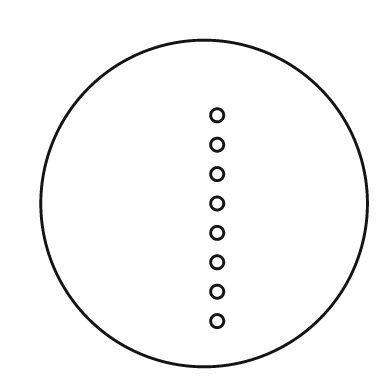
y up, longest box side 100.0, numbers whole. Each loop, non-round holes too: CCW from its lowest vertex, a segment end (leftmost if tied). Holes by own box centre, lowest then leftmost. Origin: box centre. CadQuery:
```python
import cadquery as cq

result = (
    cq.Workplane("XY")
    .moveTo(0.0, 0.0)
    .circle(50.0)
    .moveTo(4.0, -36.0)
    .circle(2.0)
    .moveTo(4.0, -27.0)
    .circle(2.0)
    .moveTo(4.0, -18.0)
    .circle(2.0)
    .moveTo(4.0, -9.0)
    .circle(2.0)
    .moveTo(4.0, 0.0)
    .circle(2.0)
    .moveTo(4.0, 9.0)
    .circle(2.0)
    .moveTo(4.0, 18.0)
    .circle(2.0)
    .moveTo(4.0, 27.0)
    .circle(2.0)
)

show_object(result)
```